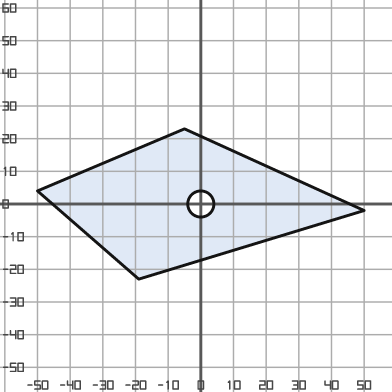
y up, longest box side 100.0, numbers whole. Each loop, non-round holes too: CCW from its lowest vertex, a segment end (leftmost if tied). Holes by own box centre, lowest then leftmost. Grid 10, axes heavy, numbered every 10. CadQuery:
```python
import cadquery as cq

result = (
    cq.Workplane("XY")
    .moveTo(-19.0, -23.0)
    .lineTo(50.0, -2.0)
    .lineTo(-5.0, 23.0)
    .lineTo(-50.0, 4.0)
    .close()
    .moveTo(0.0, 0.0)
    .circle(4.0)
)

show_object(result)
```